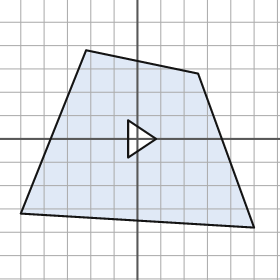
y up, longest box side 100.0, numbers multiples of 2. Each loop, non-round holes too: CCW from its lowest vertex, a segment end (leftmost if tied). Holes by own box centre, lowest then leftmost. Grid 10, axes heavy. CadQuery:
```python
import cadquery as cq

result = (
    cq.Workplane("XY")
    .moveTo(50.0, -38.0)
    .lineTo(26.0, 28.0)
    .lineTo(-22.0, 38.0)
    .lineTo(-50.0, -32.0)
    .close()
    .moveTo(-4.0, -8.0)
    .lineTo(8.0, 0.0)
    .lineTo(-4.0, 8.0)
    .close()
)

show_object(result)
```